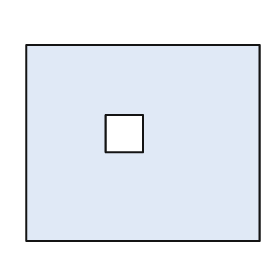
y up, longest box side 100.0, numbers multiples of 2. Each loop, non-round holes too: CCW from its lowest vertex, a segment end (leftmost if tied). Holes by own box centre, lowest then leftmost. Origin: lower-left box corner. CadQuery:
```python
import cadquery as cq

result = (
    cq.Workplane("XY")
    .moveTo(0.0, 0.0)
    .lineTo(100.0, 0.0)
    .lineTo(100.0, 84.0)
    .lineTo(0.0, 84.0)
    .close()
    .moveTo(34.0, 38.0)
    .lineTo(50.0, 38.0)
    .lineTo(50.0, 54.0)
    .lineTo(34.0, 54.0)
    .close()
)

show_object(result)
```